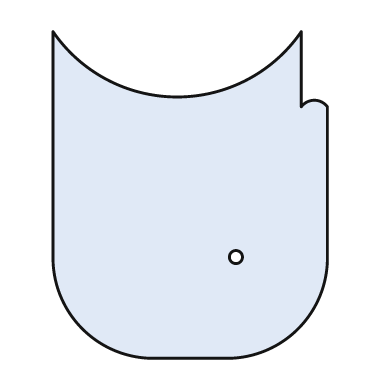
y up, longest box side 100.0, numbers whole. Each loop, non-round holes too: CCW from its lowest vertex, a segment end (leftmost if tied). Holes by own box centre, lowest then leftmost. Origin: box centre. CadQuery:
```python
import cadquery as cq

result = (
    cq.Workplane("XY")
    .moveTo(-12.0, -50.0)
    .lineTo(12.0, -50.0)
    .threePointArc((33.0, -41.0), (42.0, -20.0))
    .lineTo(42.0, 27.0)
    .threePointArc((38.0, 29.0), (34.0, 27.0))
    .lineTo(34.0, 50.0)
    .threePointArc((-4.0, 30.0), (-42.0, 50.0))
    .lineTo(-42.0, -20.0)
    .threePointArc((-33.0, -41.0), (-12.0, -50.0))
    .close()
    .moveTo(14.0, -19.0)
    .circle(2.0)
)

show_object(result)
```